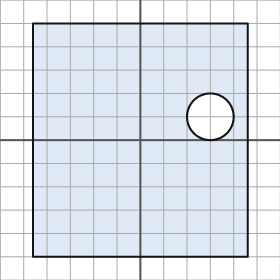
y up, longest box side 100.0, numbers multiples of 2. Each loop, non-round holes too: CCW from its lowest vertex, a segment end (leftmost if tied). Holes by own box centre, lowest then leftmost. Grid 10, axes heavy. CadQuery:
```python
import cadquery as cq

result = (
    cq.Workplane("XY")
    .moveTo(-46.0, -50.0)
    .lineTo(46.0, -50.0)
    .lineTo(46.0, 50.0)
    .lineTo(-46.0, 50.0)
    .close()
    .moveTo(30.0, 10.0)
    .circle(10.0)
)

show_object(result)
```